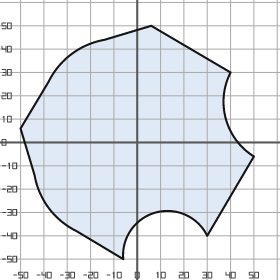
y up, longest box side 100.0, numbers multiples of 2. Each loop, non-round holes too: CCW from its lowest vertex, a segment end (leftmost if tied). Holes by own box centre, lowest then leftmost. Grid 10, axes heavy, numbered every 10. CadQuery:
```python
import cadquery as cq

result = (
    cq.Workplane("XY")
    .moveTo(-6.0, -50.0)
    .threePointArc((8.0, -30.0), (30.0, -40.0))
    .lineTo(50.0, -6.0)
    .threePointArc((38.0, 10.0), (40.0, 30.0))
    .lineTo(6.0, 50.0)
    .lineTo(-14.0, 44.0)
    .threePointArc((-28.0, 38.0), (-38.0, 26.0))
    .lineTo(-50.0, 6.0)
    .lineTo(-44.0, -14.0)
    .threePointArc((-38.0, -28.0), (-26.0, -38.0))
    .close()
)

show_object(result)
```